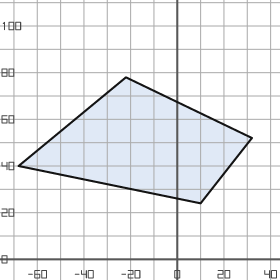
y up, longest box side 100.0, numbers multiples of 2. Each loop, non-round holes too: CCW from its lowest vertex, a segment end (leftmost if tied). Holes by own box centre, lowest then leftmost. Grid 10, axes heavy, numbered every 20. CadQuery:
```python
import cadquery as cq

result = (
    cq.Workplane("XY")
    .moveTo(10.0, 24.0)
    .lineTo(32.0, 52.0)
    .lineTo(-22.0, 78.0)
    .lineTo(-68.0, 40.0)
    .close()
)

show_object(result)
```